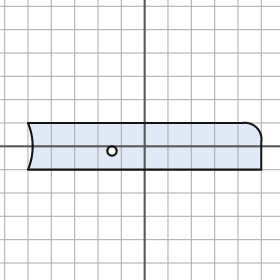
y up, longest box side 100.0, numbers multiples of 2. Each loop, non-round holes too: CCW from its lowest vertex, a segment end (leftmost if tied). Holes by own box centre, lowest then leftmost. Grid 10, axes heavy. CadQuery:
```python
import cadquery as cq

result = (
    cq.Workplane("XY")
    .moveTo(-50.0, -10.0)
    .lineTo(50.0, -10.0)
    .lineTo(50.0, 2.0)
    .threePointArc((48.0, 8.0), (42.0, 10.0))
    .lineTo(-50.0, 10.0)
    .threePointArc((-48.0, 0.0), (-50.0, -10.0))
    .close()
    .moveTo(-14.0, -2.0)
    .circle(2.0)
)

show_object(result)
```